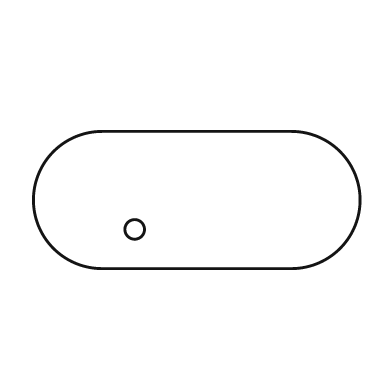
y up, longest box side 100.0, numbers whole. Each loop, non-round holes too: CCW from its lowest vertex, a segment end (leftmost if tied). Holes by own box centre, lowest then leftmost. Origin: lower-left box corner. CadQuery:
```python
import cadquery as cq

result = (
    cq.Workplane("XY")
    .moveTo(21.0, 0.0)
    .lineTo(79.0, 0.0)
    .threePointArc((100.0, 21.0), (79.0, 42.0))
    .lineTo(21.0, 42.0)
    .threePointArc((0.0, 21.0), (21.0, 0.0))
    .close()
    .moveTo(31.0, 12.0)
    .circle(3.0)
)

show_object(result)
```